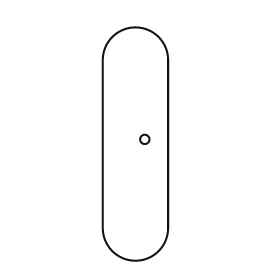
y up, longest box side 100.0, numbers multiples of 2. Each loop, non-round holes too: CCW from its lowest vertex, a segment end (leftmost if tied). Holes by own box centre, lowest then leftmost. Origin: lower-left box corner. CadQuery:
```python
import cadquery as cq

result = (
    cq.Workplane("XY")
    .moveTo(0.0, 14.0)
    .threePointArc((14.0, 0.0), (28.0, 14.0))
    .lineTo(28.0, 86.0)
    .threePointArc((14.0, 100.0), (0.0, 86.0))
    .close()
    .moveTo(18.0, 52.0)
    .circle(2.0)
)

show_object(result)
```